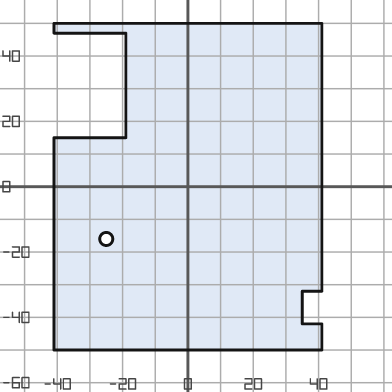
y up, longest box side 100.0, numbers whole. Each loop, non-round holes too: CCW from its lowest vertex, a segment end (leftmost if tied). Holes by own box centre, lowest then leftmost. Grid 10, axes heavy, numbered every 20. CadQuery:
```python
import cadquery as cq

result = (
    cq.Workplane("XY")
    .moveTo(-41.0, -50.0)
    .lineTo(41.0, -50.0)
    .lineTo(41.0, -42.0)
    .lineTo(35.0, -42.0)
    .lineTo(35.0, -32.0)
    .lineTo(41.0, -32.0)
    .lineTo(41.0, 50.0)
    .lineTo(-41.0, 50.0)
    .lineTo(-41.0, 47.0)
    .lineTo(-19.0, 47.0)
    .lineTo(-19.0, 15.0)
    .lineTo(-41.0, 15.0)
    .close()
    .moveTo(-25.0, -16.0)
    .circle(2.0)
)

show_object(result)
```